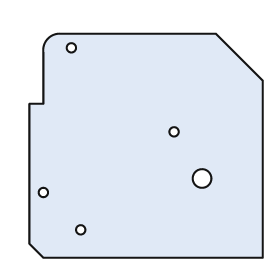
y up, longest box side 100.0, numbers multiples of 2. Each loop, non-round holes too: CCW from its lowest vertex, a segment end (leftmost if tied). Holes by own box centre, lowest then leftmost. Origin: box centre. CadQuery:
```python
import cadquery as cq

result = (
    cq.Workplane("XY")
    .moveTo(-44.0, -48.0)
    .lineTo(50.0, -48.0)
    .lineTo(50.0, 28.0)
    .lineTo(30.0, 48.0)
    .lineTo(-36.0, 48.0)
    .threePointArc((-42.0, 46.0), (-44.0, 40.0))
    .lineTo(-44.0, 18.0)
    .lineTo(-50.0, 18.0)
    .lineTo(-50.0, -42.0)
    .close()
    .moveTo(-28.0, -36.0)
    .circle(2.0)
    .moveTo(-44.0, -20.0)
    .circle(2.0)
    .moveTo(24.0, -14.0)
    .circle(4.0)
    .moveTo(12.0, 6.0)
    .circle(2.0)
    .moveTo(-32.0, 42.0)
    .circle(2.0)
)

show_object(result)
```